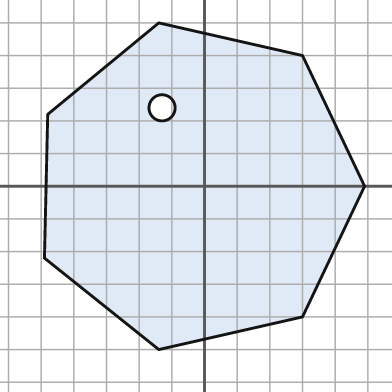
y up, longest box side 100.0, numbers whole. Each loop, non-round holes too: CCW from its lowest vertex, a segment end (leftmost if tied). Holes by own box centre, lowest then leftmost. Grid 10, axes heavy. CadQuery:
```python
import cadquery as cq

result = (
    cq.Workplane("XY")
    .moveTo(-14.0, -50.0)
    .lineTo(30.0, -40.0)
    .lineTo(49.0, 0.0)
    .lineTo(30.0, 40.0)
    .lineTo(-14.0, 50.0)
    .lineTo(-48.0, 22.0)
    .lineTo(-49.0, -22.0)
    .close()
    .moveTo(-13.0, 24.0)
    .circle(4.0)
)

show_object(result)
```